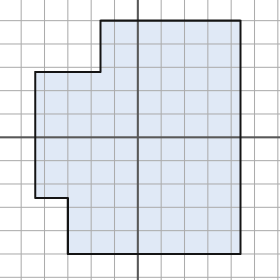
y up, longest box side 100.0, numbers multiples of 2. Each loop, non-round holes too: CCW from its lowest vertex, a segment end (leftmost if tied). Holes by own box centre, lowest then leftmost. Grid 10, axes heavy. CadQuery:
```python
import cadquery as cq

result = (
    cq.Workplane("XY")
    .moveTo(-30.0, -50.0)
    .lineTo(44.0, -50.0)
    .lineTo(44.0, 50.0)
    .lineTo(-16.0, 50.0)
    .lineTo(-16.0, 28.0)
    .lineTo(-44.0, 28.0)
    .lineTo(-44.0, -26.0)
    .lineTo(-30.0, -26.0)
    .close()
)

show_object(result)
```